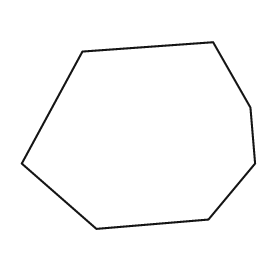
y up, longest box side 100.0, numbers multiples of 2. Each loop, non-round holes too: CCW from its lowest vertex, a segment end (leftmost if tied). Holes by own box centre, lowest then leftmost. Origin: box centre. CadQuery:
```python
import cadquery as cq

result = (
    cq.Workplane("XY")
    .moveTo(-18.0, -40.0)
    .lineTo(30.0, -36.0)
    .lineTo(50.0, -12.0)
    .lineTo(48.0, 12.0)
    .lineTo(32.0, 40.0)
    .lineTo(-24.0, 36.0)
    .lineTo(-50.0, -12.0)
    .close()
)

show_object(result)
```